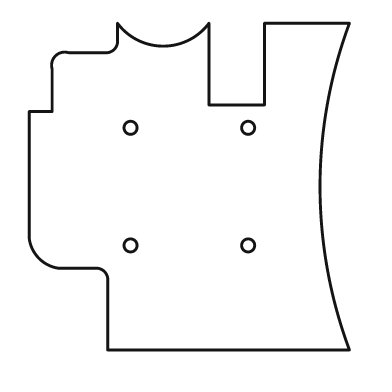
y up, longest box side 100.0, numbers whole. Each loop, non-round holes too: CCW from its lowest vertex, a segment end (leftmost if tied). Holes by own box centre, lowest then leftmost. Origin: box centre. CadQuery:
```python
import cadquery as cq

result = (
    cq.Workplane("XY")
    .moveTo(-25.0, -50.0)
    .lineTo(49.0, -50.0)
    .threePointArc((40.0, 0.0), (49.0, 50.0))
    .lineTo(23.0, 50.0)
    .lineTo(23.0, 25.0)
    .lineTo(6.0, 25.0)
    .lineTo(6.0, 50.0)
    .threePointArc((-8.0, 43.0), (-22.0, 50.0))
    .lineTo(-22.0, 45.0)
    .threePointArc((-23.0, 42.0), (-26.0, 41.0))
    .lineTo(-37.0, 41.0)
    .threePointArc((-41.0, 40.0), (-42.0, 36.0))
    .lineTo(-42.0, 23.0)
    .lineTo(-49.0, 23.0)
    .lineTo(-49.0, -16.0)
    .threePointArc((-46.0, -22.0), (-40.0, -25.0))
    .lineTo(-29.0, -25.0)
    .threePointArc((-26.0, -26.0), (-25.0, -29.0))
    .close()
    .moveTo(-18.0, -18.0)
    .circle(2.0)
    .moveTo(18.0, -18.0)
    .circle(2.0)
    .moveTo(-18.0, 18.0)
    .circle(2.0)
    .moveTo(18.0, 18.0)
    .circle(2.0)
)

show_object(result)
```